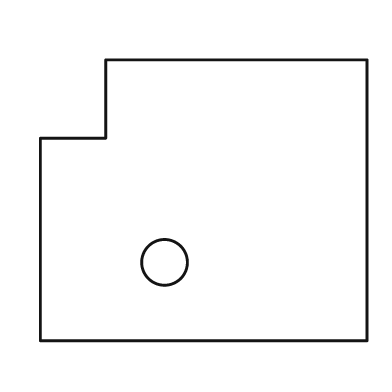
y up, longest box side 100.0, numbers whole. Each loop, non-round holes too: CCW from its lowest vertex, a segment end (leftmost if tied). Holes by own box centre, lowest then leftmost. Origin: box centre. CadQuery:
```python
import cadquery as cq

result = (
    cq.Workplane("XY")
    .moveTo(-50.0, -43.0)
    .lineTo(50.0, -43.0)
    .lineTo(50.0, 43.0)
    .lineTo(-30.0, 43.0)
    .lineTo(-30.0, 19.0)
    .lineTo(-50.0, 19.0)
    .close()
    .moveTo(-12.0, -19.0)
    .circle(7.0)
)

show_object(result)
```